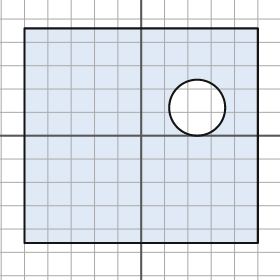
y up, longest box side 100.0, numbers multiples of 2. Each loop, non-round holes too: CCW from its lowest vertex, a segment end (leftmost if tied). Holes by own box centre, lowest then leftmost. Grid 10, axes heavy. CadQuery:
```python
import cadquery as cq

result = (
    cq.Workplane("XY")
    .moveTo(-50.0, -46.0)
    .lineTo(50.0, -46.0)
    .lineTo(50.0, 46.0)
    .lineTo(-50.0, 46.0)
    .close()
    .moveTo(24.0, 12.0)
    .circle(12.0)
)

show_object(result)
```